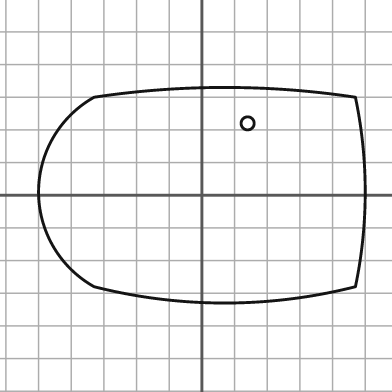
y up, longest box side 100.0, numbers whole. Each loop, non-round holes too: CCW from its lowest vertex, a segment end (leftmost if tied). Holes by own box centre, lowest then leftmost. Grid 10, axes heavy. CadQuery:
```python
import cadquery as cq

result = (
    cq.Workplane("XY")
    .moveTo(-33.0, -28.0)
    .threePointArc((7.0, -33.0), (47.0, -28.0))
    .threePointArc((50.0, 1.0), (47.0, 30.0))
    .threePointArc((7.0, 33.0), (-33.0, 30.0))
    .threePointArc((-50.0, 1.0), (-33.0, -28.0))
    .close()
    .moveTo(14.0, 22.0)
    .circle(2.0)
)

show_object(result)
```